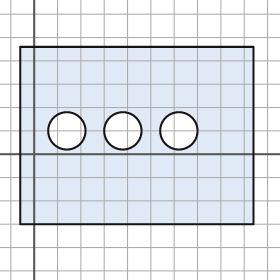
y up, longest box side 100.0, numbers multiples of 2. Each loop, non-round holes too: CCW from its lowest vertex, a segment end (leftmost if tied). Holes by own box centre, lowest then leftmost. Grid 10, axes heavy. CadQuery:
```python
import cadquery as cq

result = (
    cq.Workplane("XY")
    .moveTo(-6.0, -30.0)
    .lineTo(94.0, -30.0)
    .lineTo(94.0, 46.0)
    .lineTo(-6.0, 46.0)
    .close()
    .moveTo(14.0, 10.0)
    .circle(8.0)
    .moveTo(38.0, 10.0)
    .circle(8.0)
    .moveTo(62.0, 10.0)
    .circle(8.0)
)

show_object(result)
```